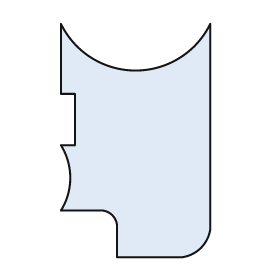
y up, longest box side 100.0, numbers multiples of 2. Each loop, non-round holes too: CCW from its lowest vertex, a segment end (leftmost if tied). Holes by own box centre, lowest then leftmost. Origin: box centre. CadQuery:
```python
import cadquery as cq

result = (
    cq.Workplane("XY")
    .moveTo(-8.0, -50.0)
    .lineTo(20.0, -50.0)
    .threePointArc((28.0, -46.0), (32.0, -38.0))
    .lineTo(32.0, 50.0)
    .threePointArc((0.0, 30.0), (-32.0, 50.0))
    .lineTo(-32.0, 20.0)
    .lineTo(-26.0, 20.0)
    .lineTo(-26.0, -2.0)
    .lineTo(-32.0, -2.0)
    .threePointArc((-28.0, -16.0), (-32.0, -30.0))
    .lineTo(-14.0, -30.0)
    .threePointArc((-10.0, -32.0), (-8.0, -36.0))
    .close()
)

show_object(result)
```